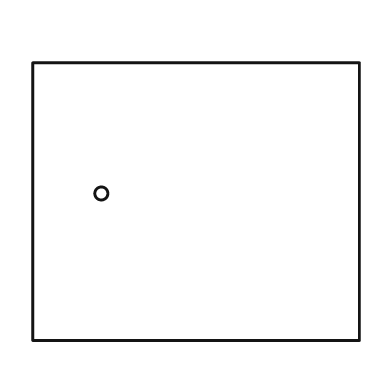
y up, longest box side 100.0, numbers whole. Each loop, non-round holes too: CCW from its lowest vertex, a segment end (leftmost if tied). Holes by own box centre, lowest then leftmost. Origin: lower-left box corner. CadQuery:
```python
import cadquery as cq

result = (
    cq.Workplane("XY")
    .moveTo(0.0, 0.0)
    .lineTo(100.0, 0.0)
    .lineTo(100.0, 85.0)
    .lineTo(0.0, 85.0)
    .close()
    .moveTo(21.0, 45.0)
    .circle(2.0)
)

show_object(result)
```